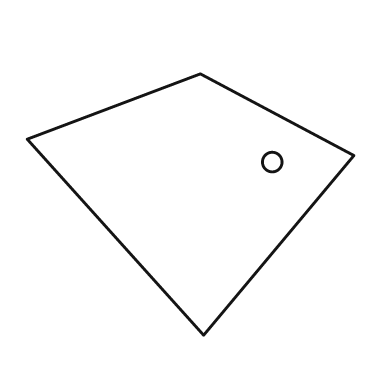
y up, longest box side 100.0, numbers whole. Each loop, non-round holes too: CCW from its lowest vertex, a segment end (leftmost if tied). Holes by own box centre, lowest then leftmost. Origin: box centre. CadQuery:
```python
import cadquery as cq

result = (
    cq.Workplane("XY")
    .moveTo(4.0, -40.0)
    .lineTo(50.0, 15.0)
    .lineTo(3.0, 40.0)
    .lineTo(-50.0, 20.0)
    .close()
    .moveTo(25.0, 13.0)
    .circle(3.0)
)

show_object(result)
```